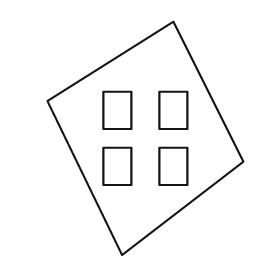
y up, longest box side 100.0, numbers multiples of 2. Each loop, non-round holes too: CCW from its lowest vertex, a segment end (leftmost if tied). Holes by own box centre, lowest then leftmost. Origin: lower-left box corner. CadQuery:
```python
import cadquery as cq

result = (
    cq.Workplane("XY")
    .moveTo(32.0, 0.0)
    .lineTo(84.0, 40.0)
    .lineTo(54.0, 100.0)
    .lineTo(0.0, 66.0)
    .close()
    .moveTo(24.0, 30.0)
    .lineTo(36.0, 30.0)
    .lineTo(36.0, 46.0)
    .lineTo(24.0, 46.0)
    .close()
    .moveTo(48.0, 30.0)
    .lineTo(60.0, 30.0)
    .lineTo(60.0, 46.0)
    .lineTo(48.0, 46.0)
    .close()
    .moveTo(24.0, 54.0)
    .lineTo(36.0, 54.0)
    .lineTo(36.0, 70.0)
    .lineTo(24.0, 70.0)
    .close()
    .moveTo(48.0, 54.0)
    .lineTo(60.0, 54.0)
    .lineTo(60.0, 70.0)
    .lineTo(48.0, 70.0)
    .close()
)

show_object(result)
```